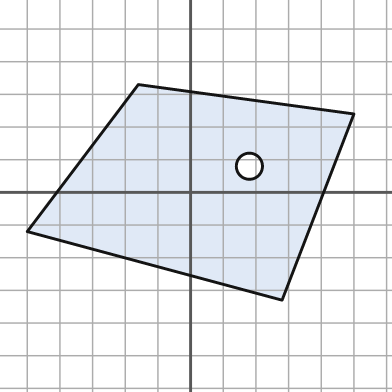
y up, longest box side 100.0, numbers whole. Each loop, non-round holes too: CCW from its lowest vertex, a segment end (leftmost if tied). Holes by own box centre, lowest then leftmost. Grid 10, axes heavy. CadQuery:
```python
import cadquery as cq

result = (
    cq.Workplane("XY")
    .moveTo(28.0, -33.0)
    .lineTo(50.0, 24.0)
    .lineTo(-16.0, 33.0)
    .lineTo(-50.0, -12.0)
    .close()
    .moveTo(18.0, 8.0)
    .circle(4.0)
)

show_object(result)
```